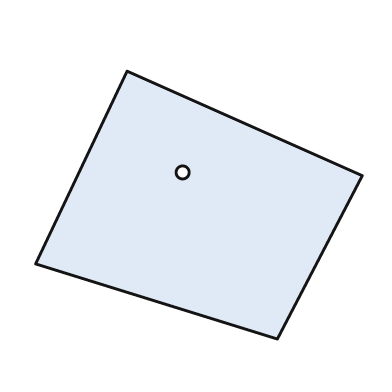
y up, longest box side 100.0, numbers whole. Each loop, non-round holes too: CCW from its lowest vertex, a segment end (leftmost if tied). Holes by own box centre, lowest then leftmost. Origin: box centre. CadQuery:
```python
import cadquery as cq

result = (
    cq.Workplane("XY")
    .moveTo(24.0, -41.0)
    .lineTo(50.0, 9.0)
    .lineTo(-22.0, 41.0)
    .lineTo(-50.0, -18.0)
    .close()
    .moveTo(-5.0, 10.0)
    .circle(2.0)
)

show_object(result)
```